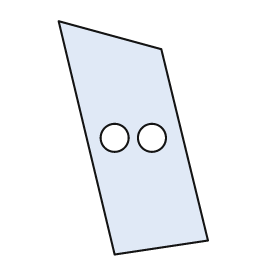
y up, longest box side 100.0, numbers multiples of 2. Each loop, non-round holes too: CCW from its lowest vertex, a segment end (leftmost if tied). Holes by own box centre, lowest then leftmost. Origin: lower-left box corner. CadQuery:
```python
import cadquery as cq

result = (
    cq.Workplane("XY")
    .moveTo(24.0, 0.0)
    .lineTo(64.0, 6.0)
    .lineTo(44.0, 88.0)
    .lineTo(0.0, 100.0)
    .close()
    .moveTo(24.0, 50.0)
    .circle(6.0)
    .moveTo(40.0, 50.0)
    .circle(6.0)
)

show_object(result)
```